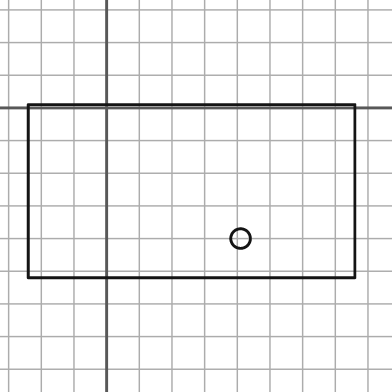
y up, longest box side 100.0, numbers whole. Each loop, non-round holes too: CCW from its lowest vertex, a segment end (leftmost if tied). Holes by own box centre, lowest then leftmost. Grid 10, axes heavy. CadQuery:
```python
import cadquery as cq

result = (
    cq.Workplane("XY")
    .moveTo(-24.0, -52.0)
    .lineTo(76.0, -52.0)
    .lineTo(76.0, 1.0)
    .lineTo(-24.0, 1.0)
    .close()
    .moveTo(41.0, -40.0)
    .circle(3.0)
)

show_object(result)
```